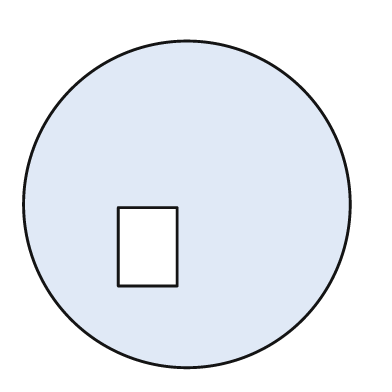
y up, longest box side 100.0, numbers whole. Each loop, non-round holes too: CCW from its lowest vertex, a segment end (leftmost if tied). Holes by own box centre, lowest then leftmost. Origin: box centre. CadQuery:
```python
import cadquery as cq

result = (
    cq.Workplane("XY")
    .moveTo(0.0, 0.0)
    .circle(50.0)
    .moveTo(-21.0, -25.0)
    .lineTo(-3.0, -25.0)
    .lineTo(-3.0, -1.0)
    .lineTo(-21.0, -1.0)
    .close()
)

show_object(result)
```